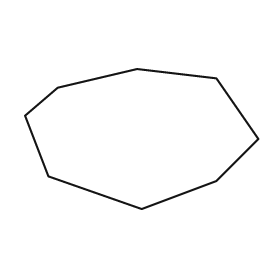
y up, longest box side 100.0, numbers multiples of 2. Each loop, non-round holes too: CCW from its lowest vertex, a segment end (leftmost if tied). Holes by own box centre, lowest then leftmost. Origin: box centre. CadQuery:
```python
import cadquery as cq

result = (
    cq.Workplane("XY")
    .moveTo(0.0, -30.0)
    .lineTo(32.0, -18.0)
    .lineTo(50.0, 0.0)
    .lineTo(32.0, 26.0)
    .lineTo(-2.0, 30.0)
    .lineTo(-36.0, 22.0)
    .lineTo(-50.0, 10.0)
    .lineTo(-40.0, -16.0)
    .close()
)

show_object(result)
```